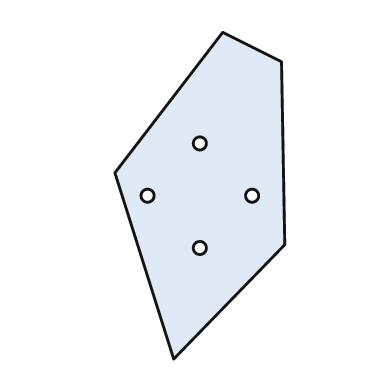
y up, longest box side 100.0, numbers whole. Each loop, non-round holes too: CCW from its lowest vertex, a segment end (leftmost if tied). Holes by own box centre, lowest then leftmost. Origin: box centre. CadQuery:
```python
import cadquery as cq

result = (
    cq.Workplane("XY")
    .moveTo(-8.0, -50.0)
    .lineTo(26.0, -15.0)
    .lineTo(25.0, 41.0)
    .lineTo(7.0, 50.0)
    .lineTo(-26.0, 7.0)
    .close()
    .moveTo(0.0, -16.0)
    .circle(2.0)
    .moveTo(-16.0, 0.0)
    .circle(2.0)
    .moveTo(16.0, 0.0)
    .circle(2.0)
    .moveTo(0.0, 16.0)
    .circle(2.0)
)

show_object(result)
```